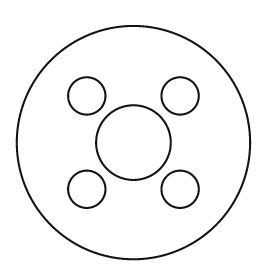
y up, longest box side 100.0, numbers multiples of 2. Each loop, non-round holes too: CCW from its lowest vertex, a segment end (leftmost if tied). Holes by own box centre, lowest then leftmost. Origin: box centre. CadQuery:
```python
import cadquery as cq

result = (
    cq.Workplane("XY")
    .moveTo(0.0, 0.0)
    .circle(50.0)
    .moveTo(-20.0, -20.0)
    .circle(8.0)
    .moveTo(20.0, -20.0)
    .circle(8.0)
    .moveTo(0.0, 0.0)
    .circle(16.0)
    .moveTo(-20.0, 20.0)
    .circle(8.0)
    .moveTo(20.0, 20.0)
    .circle(8.0)
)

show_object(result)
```